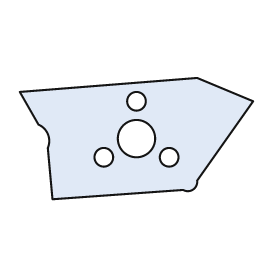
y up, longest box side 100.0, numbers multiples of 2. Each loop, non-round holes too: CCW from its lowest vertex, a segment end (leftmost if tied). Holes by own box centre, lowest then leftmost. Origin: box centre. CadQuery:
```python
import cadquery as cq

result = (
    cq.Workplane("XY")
    .moveTo(-36.0, -26.0)
    .lineTo(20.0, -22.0)
    .threePointArc((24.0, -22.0), (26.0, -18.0))
    .lineTo(50.0, 16.0)
    .lineTo(26.0, 26.0)
    .lineTo(-50.0, 20.0)
    .lineTo(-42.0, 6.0)
    .threePointArc((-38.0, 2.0), (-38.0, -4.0))
    .close()
    .moveTo(-14.0, -8.0)
    .circle(4.0)
    .moveTo(14.0, -8.0)
    .circle(4.0)
    .moveTo(0.0, 0.0)
    .circle(8.0)
    .moveTo(0.0, 16.0)
    .circle(4.0)
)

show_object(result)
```